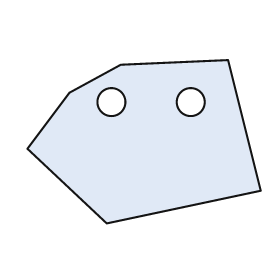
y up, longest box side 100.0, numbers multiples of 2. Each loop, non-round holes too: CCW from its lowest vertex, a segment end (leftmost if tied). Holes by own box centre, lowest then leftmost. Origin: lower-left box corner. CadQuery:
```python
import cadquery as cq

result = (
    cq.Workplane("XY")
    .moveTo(34.0, 0.0)
    .lineTo(100.0, 14.0)
    .lineTo(86.0, 70.0)
    .lineTo(40.0, 68.0)
    .lineTo(18.0, 56.0)
    .lineTo(0.0, 32.0)
    .close()
    .moveTo(36.0, 52.0)
    .circle(6.0)
    .moveTo(70.0, 52.0)
    .circle(6.0)
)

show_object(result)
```